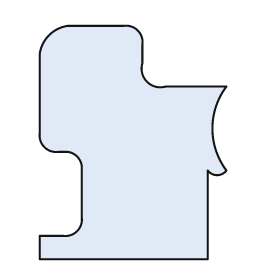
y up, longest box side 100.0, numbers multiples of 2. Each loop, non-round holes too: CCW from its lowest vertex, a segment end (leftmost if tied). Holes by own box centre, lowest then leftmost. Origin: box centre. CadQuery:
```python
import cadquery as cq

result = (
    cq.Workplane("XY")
    .moveTo(-40.0, -50.0)
    .lineTo(32.0, -50.0)
    .lineTo(32.0, -12.0)
    .threePointArc((36.0, -14.0), (40.0, -12.0))
    .threePointArc((34.0, 6.0), (40.0, 24.0))
    .lineTo(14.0, 24.0)
    .threePointArc((6.0, 26.0), (4.0, 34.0))
    .lineTo(4.0, 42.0)
    .threePointArc((2.0, 48.0), (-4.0, 50.0))
    .lineTo(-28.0, 50.0)
    .threePointArc((-36.0, 46.0), (-40.0, 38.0))
    .lineTo(-40.0, 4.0)
    .threePointArc((-38.0, -2.0), (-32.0, -4.0))
    .lineTo(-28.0, -4.0)
    .threePointArc((-24.0, -6.0), (-22.0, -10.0))
    .lineTo(-22.0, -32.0)
    .threePointArc((-24.0, -38.0), (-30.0, -40.0))
    .lineTo(-40.0, -40.0)
    .close()
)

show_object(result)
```